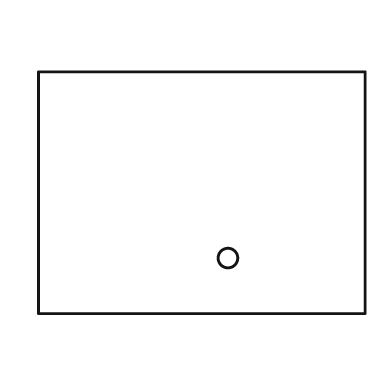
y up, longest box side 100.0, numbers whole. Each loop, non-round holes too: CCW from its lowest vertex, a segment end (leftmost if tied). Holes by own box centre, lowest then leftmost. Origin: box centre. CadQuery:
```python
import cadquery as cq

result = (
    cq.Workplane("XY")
    .moveTo(-50.0, -37.0)
    .lineTo(50.0, -37.0)
    .lineTo(50.0, 37.0)
    .lineTo(-50.0, 37.0)
    .close()
    .moveTo(8.0, -20.0)
    .circle(3.0)
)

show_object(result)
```